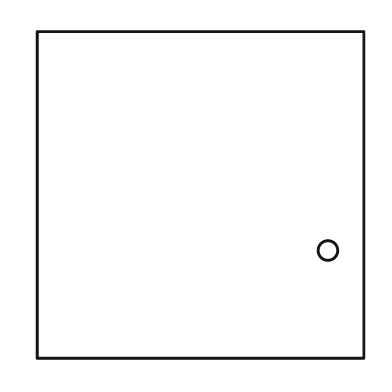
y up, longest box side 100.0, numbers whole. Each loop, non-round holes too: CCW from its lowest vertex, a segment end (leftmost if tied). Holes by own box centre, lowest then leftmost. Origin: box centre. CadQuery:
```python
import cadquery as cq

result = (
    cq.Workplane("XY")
    .moveTo(-50.0, -50.0)
    .lineTo(50.0, -50.0)
    .lineTo(50.0, 50.0)
    .lineTo(-50.0, 50.0)
    .close()
    .moveTo(39.0, -17.0)
    .circle(3.0)
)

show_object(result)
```